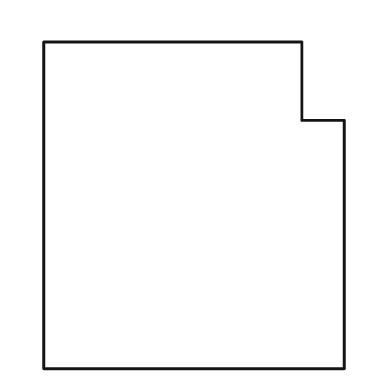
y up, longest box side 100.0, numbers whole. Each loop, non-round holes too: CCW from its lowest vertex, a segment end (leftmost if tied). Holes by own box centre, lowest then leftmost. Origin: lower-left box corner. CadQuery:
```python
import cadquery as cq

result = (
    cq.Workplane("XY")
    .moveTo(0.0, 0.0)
    .lineTo(92.0, 0.0)
    .lineTo(92.0, 76.0)
    .lineTo(79.0, 76.0)
    .lineTo(79.0, 100.0)
    .lineTo(0.0, 100.0)
    .close()
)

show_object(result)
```